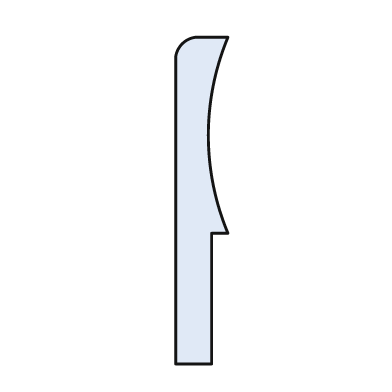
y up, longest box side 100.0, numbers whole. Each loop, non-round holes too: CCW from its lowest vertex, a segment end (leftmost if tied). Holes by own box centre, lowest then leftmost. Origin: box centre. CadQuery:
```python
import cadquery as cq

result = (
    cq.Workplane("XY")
    .moveTo(-8.0, -50.0)
    .lineTo(3.0, -50.0)
    .lineTo(3.0, -10.0)
    .lineTo(8.0, -10.0)
    .threePointArc((2.0, 20.0), (8.0, 50.0))
    .lineTo(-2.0, 50.0)
    .threePointArc((-6.0, 48.0), (-8.0, 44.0))
    .close()
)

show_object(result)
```